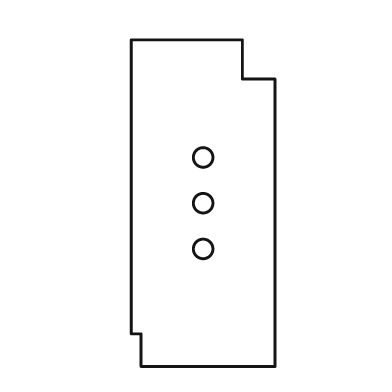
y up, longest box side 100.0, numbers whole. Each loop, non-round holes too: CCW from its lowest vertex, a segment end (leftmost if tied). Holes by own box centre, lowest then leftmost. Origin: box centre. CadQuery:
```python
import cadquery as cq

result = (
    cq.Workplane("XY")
    .moveTo(-19.0, -50.0)
    .lineTo(22.0, -50.0)
    .lineTo(22.0, 38.0)
    .lineTo(12.0, 38.0)
    .lineTo(12.0, 50.0)
    .lineTo(-22.0, 50.0)
    .lineTo(-22.0, -40.0)
    .lineTo(-19.0, -40.0)
    .close()
    .moveTo(0.0, -14.0)
    .circle(3.0)
    .moveTo(0.0, 0.0)
    .circle(3.0)
    .moveTo(0.0, 14.0)
    .circle(3.0)
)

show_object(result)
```